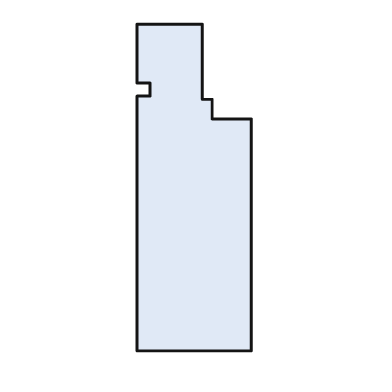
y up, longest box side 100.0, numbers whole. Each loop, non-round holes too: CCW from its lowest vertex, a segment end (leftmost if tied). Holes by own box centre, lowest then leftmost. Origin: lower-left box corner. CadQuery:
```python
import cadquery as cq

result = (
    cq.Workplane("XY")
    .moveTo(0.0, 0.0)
    .lineTo(35.0, 0.0)
    .lineTo(35.0, 71.0)
    .lineTo(23.0, 71.0)
    .lineTo(23.0, 77.0)
    .lineTo(20.0, 77.0)
    .lineTo(20.0, 100.0)
    .lineTo(0.0, 100.0)
    .lineTo(0.0, 82.0)
    .lineTo(4.0, 82.0)
    .lineTo(4.0, 78.0)
    .lineTo(0.0, 78.0)
    .close()
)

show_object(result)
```